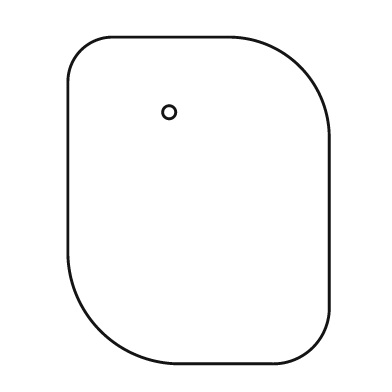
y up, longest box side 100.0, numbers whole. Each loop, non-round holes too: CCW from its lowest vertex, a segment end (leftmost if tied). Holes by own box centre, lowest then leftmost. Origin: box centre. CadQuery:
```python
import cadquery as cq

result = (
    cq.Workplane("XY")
    .moveTo(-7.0, -50.0)
    .lineTo(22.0, -50.0)
    .threePointArc((35.0, -45.0), (40.0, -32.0))
    .lineTo(40.0, 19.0)
    .threePointArc((31.0, 41.0), (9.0, 50.0))
    .lineTo(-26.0, 50.0)
    .threePointArc((-36.0, 46.0), (-40.0, 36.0))
    .lineTo(-40.0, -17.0)
    .threePointArc((-30.0, -40.0), (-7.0, -50.0))
    .close()
    .moveTo(-9.0, 27.0)
    .circle(2.0)
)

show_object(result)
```